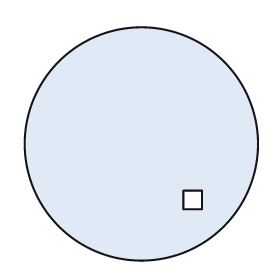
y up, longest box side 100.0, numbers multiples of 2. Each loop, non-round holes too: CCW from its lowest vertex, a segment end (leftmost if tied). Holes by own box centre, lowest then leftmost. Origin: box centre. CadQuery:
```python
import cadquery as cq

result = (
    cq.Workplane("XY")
    .moveTo(0.0, 0.0)
    .circle(50.0)
    .moveTo(18.0, -28.0)
    .lineTo(26.0, -28.0)
    .lineTo(26.0, -20.0)
    .lineTo(18.0, -20.0)
    .close()
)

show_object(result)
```